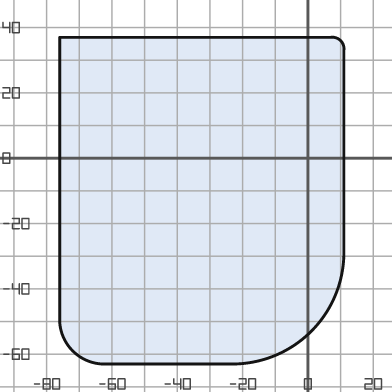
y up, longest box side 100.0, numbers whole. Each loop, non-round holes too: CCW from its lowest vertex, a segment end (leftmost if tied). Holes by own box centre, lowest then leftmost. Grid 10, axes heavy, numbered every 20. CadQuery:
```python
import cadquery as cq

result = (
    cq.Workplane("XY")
    .moveTo(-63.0, -63.0)
    .lineTo(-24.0, -63.0)
    .threePointArc((1.0, -53.0), (11.0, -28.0))
    .lineTo(11.0, 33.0)
    .threePointArc((10.0, 36.0), (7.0, 37.0))
    .lineTo(-76.0, 37.0)
    .lineTo(-76.0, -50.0)
    .threePointArc((-72.0, -59.0), (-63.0, -63.0))
    .close()
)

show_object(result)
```